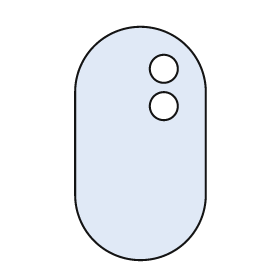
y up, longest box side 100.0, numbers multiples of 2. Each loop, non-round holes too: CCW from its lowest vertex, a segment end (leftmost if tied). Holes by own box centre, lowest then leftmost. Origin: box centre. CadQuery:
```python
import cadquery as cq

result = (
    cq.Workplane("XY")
    .moveTo(-28.0, -22.0)
    .threePointArc((0.0, -50.0), (28.0, -22.0))
    .lineTo(28.0, 22.0)
    .threePointArc((0.0, 50.0), (-28.0, 22.0))
    .close()
    .moveTo(10.0, 16.0)
    .circle(6.0)
    .moveTo(10.0, 32.0)
    .circle(6.0)
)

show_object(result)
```